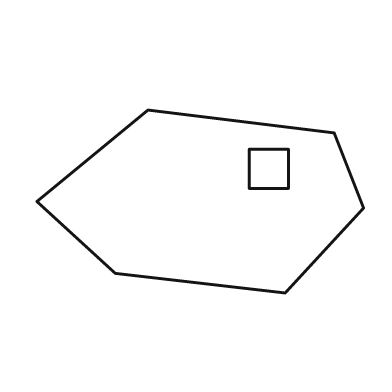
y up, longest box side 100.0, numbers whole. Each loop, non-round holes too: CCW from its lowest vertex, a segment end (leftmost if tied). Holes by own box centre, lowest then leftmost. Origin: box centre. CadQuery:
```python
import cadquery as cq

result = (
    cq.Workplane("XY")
    .moveTo(26.0, -28.0)
    .lineTo(50.0, -2.0)
    .lineTo(41.0, 21.0)
    .lineTo(-16.0, 28.0)
    .lineTo(-50.0, 0.0)
    .lineTo(-26.0, -22.0)
    .close()
    .moveTo(15.0, 4.0)
    .lineTo(27.0, 4.0)
    .lineTo(27.0, 16.0)
    .lineTo(15.0, 16.0)
    .close()
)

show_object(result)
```